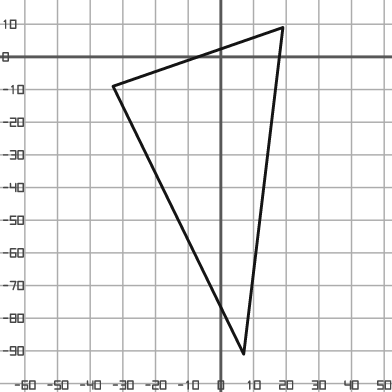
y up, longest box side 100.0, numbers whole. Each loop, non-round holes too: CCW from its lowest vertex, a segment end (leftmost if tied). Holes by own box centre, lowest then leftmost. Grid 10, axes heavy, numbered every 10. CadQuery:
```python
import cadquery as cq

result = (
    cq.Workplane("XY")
    .moveTo(7.0, -91.0)
    .lineTo(19.0, 9.0)
    .lineTo(-33.0, -9.0)
    .close()
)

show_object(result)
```